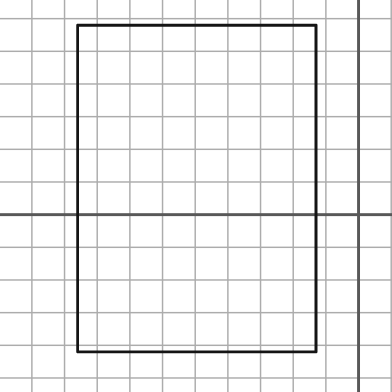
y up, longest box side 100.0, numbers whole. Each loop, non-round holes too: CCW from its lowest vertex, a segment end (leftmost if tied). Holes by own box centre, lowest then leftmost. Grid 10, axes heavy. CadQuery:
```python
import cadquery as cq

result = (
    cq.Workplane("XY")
    .moveTo(-86.0, -42.0)
    .lineTo(-13.0, -42.0)
    .lineTo(-13.0, 58.0)
    .lineTo(-86.0, 58.0)
    .close()
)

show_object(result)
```